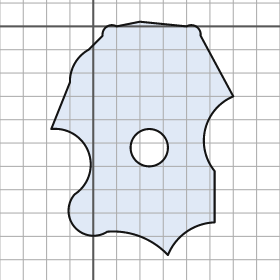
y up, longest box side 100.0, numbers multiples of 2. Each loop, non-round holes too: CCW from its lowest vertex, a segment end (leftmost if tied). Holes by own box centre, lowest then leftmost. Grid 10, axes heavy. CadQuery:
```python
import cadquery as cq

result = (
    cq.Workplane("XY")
    .moveTo(32.0, -98.0)
    .threePointArc((40.0, -88.0), (52.0, -84.0))
    .lineTo(52.0, -62.0)
    .threePointArc((48.0, -44.0), (60.0, -30.0))
    .lineTo(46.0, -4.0)
    .threePointArc((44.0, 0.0), (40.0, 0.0))
    .lineTo(20.0, 2.0)
    .lineTo(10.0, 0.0)
    .threePointArc((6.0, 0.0), (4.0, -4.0))
    .lineTo(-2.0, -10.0)
    .threePointArc((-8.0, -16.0), (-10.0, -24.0))
    .lineTo(-18.0, -44.0)
    .threePointArc((-2.0, -54.0), (-8.0, -72.0))
    .threePointArc((-8.0, -86.0), (6.0, -88.0))
    .threePointArc((20.0, -90.0), (32.0, -98.0))
    .close()
    .moveTo(24.0, -52.0)
    .circle(8.0)
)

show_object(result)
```